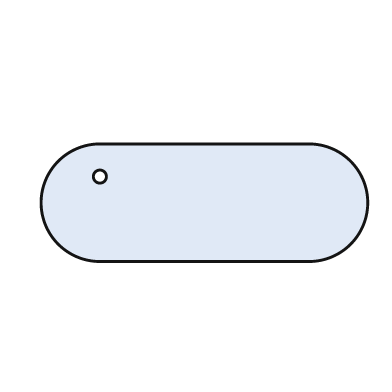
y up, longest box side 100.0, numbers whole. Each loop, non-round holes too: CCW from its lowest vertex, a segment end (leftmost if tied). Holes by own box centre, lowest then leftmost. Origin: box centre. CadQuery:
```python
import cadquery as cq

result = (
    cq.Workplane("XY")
    .moveTo(-32.0, -18.0)
    .lineTo(32.0, -18.0)
    .threePointArc((50.0, 0.0), (32.0, 18.0))
    .lineTo(-32.0, 18.0)
    .threePointArc((-50.0, 0.0), (-32.0, -18.0))
    .close()
    .moveTo(-32.0, 8.0)
    .circle(2.0)
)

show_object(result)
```